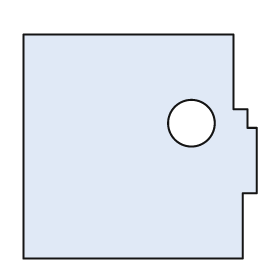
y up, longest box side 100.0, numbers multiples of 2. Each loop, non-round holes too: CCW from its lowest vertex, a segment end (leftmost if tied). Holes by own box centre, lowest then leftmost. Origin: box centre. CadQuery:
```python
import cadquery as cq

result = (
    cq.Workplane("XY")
    .moveTo(-50.0, -48.0)
    .lineTo(44.0, -48.0)
    .lineTo(44.0, -20.0)
    .lineTo(50.0, -20.0)
    .lineTo(50.0, 8.0)
    .lineTo(46.0, 8.0)
    .lineTo(46.0, 16.0)
    .lineTo(40.0, 16.0)
    .lineTo(40.0, 48.0)
    .lineTo(-50.0, 48.0)
    .close()
    .moveTo(22.0, 10.0)
    .circle(10.0)
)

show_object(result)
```